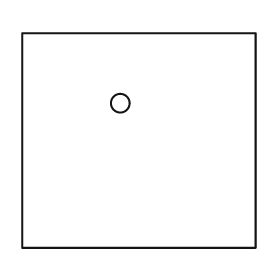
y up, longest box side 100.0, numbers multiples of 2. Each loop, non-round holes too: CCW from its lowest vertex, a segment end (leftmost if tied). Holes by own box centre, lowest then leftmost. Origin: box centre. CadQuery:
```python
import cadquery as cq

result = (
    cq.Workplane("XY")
    .moveTo(-50.0, -46.0)
    .lineTo(50.0, -46.0)
    .lineTo(50.0, 46.0)
    .lineTo(-50.0, 46.0)
    .close()
    .moveTo(-8.0, 16.0)
    .circle(4.0)
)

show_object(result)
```